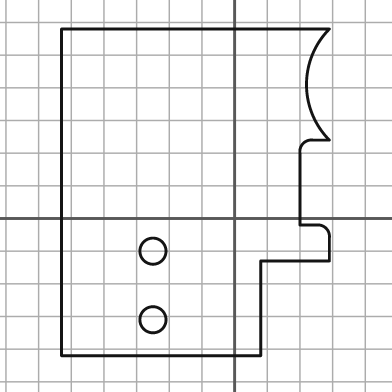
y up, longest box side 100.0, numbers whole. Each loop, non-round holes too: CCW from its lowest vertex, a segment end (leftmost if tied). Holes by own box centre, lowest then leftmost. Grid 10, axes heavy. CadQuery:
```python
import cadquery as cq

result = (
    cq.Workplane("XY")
    .moveTo(-53.0, -42.0)
    .lineTo(8.0, -42.0)
    .lineTo(8.0, -13.0)
    .lineTo(29.0, -13.0)
    .lineTo(29.0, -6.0)
    .threePointArc((28.0, -3.0), (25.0, -2.0))
    .lineTo(20.0, -2.0)
    .lineTo(20.0, 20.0)
    .threePointArc((21.0, 23.0), (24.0, 24.0))
    .lineTo(29.0, 24.0)
    .threePointArc((22.0, 41.0), (29.0, 58.0))
    .lineTo(-53.0, 58.0)
    .close()
    .moveTo(-25.0, -31.0)
    .circle(4.0)
    .moveTo(-25.0, -10.0)
    .circle(4.0)
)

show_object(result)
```